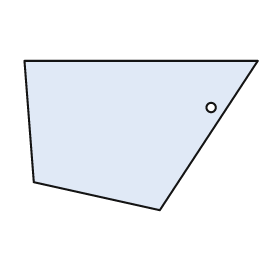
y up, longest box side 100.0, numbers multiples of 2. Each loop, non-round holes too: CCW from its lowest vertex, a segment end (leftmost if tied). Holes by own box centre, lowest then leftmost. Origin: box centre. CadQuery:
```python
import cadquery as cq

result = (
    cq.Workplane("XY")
    .moveTo(8.0, -32.0)
    .lineTo(50.0, 32.0)
    .lineTo(-50.0, 32.0)
    .lineTo(-46.0, -20.0)
    .close()
    .moveTo(30.0, 12.0)
    .circle(2.0)
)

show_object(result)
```